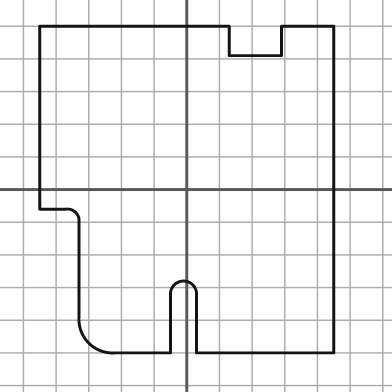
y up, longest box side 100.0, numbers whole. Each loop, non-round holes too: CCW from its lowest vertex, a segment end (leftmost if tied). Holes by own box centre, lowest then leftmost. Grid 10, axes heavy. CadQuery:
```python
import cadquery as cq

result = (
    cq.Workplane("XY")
    .moveTo(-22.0, -50.0)
    .lineTo(-5.0, -50.0)
    .lineTo(-5.0, -32.0)
    .threePointArc((-1.0, -28.0), (3.0, -32.0))
    .lineTo(3.0, -50.0)
    .lineTo(45.0, -50.0)
    .lineTo(45.0, 50.0)
    .lineTo(29.0, 50.0)
    .lineTo(29.0, 41.0)
    .lineTo(13.0, 41.0)
    .lineTo(13.0, 50.0)
    .lineTo(-45.0, 50.0)
    .lineTo(-45.0, -6.0)
    .lineTo(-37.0, -6.0)
    .threePointArc((-34.0, -7.0), (-33.0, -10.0))
    .lineTo(-33.0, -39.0)
    .threePointArc((-30.0, -47.0), (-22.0, -50.0))
    .close()
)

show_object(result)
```